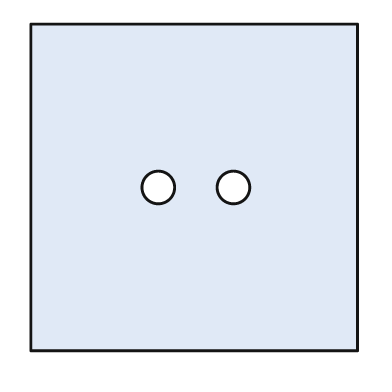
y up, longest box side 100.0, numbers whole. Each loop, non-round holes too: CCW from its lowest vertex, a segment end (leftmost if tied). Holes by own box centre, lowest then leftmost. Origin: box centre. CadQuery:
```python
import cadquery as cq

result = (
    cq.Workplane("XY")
    .moveTo(-50.0, -50.0)
    .lineTo(50.0, -50.0)
    .lineTo(50.0, 50.0)
    .lineTo(-50.0, 50.0)
    .close()
    .moveTo(-11.0, 0.0)
    .circle(5.0)
    .moveTo(12.0, 0.0)
    .circle(5.0)
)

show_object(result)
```